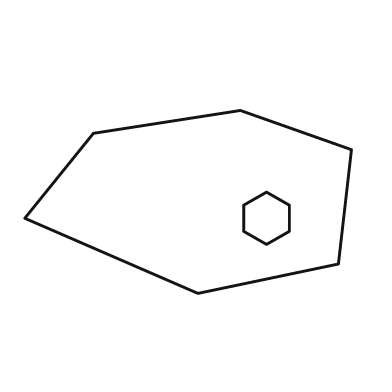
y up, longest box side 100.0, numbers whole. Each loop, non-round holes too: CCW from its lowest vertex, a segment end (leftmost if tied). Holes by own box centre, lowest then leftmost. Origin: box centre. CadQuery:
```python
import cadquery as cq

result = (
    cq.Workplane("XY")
    .moveTo(3.0, -28.0)
    .lineTo(46.0, -19.0)
    .lineTo(50.0, 16.0)
    .lineTo(16.0, 28.0)
    .lineTo(-29.0, 21.0)
    .lineTo(-50.0, -5.0)
    .close()
    .moveTo(24.0, -13.0)
    .lineTo(31.0, -9.0)
    .lineTo(31.0, -1.0)
    .lineTo(24.0, 3.0)
    .lineTo(17.0, -1.0)
    .lineTo(17.0, -9.0)
    .close()
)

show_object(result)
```